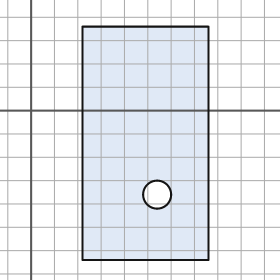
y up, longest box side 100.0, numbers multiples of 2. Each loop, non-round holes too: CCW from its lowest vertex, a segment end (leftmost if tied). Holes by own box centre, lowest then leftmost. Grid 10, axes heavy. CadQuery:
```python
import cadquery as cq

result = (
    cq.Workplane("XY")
    .moveTo(22.0, -64.0)
    .lineTo(76.0, -64.0)
    .lineTo(76.0, 36.0)
    .lineTo(22.0, 36.0)
    .close()
    .moveTo(54.0, -36.0)
    .circle(6.0)
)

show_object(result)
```